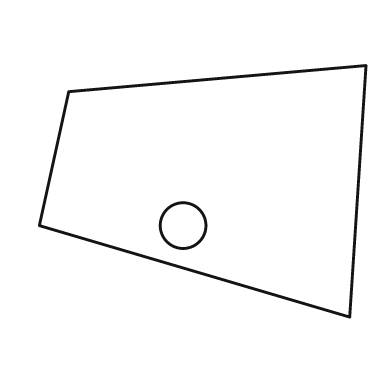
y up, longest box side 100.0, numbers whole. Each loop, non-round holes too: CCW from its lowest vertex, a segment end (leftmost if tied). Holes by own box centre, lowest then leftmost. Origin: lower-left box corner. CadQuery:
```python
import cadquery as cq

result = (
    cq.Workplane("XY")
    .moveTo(95.0, 0.0)
    .lineTo(100.0, 77.0)
    .lineTo(9.0, 69.0)
    .lineTo(0.0, 28.0)
    .close()
    .moveTo(44.0, 28.0)
    .circle(7.0)
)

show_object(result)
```